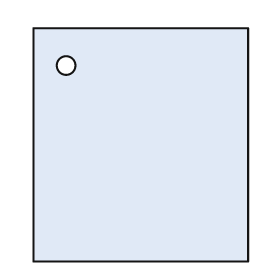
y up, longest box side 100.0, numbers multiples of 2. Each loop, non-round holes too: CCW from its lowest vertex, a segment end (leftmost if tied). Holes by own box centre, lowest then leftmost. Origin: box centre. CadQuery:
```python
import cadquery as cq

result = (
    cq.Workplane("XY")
    .moveTo(-46.0, -50.0)
    .lineTo(46.0, -50.0)
    .lineTo(46.0, 50.0)
    .lineTo(-46.0, 50.0)
    .close()
    .moveTo(-32.0, 34.0)
    .circle(4.0)
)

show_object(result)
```